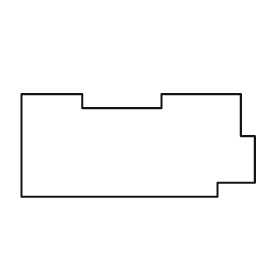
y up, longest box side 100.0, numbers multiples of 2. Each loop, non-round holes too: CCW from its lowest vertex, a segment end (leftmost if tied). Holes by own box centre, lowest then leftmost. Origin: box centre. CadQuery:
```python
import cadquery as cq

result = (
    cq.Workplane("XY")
    .moveTo(-50.0, -22.0)
    .lineTo(34.0, -22.0)
    .lineTo(34.0, -16.0)
    .lineTo(50.0, -16.0)
    .lineTo(50.0, 4.0)
    .lineTo(44.0, 4.0)
    .lineTo(44.0, 22.0)
    .lineTo(10.0, 22.0)
    .lineTo(10.0, 16.0)
    .lineTo(-24.0, 16.0)
    .lineTo(-24.0, 22.0)
    .lineTo(-50.0, 22.0)
    .close()
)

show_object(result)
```